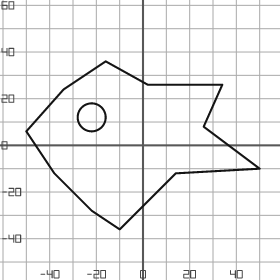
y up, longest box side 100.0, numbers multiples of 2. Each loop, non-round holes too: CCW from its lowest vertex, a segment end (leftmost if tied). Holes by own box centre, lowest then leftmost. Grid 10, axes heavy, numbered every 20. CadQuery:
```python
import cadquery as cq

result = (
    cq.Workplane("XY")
    .moveTo(-10.0, -36.0)
    .lineTo(14.0, -12.0)
    .lineTo(50.0, -10.0)
    .lineTo(26.0, 8.0)
    .lineTo(34.0, 26.0)
    .lineTo(2.0, 26.0)
    .lineTo(-16.0, 36.0)
    .lineTo(-34.0, 24.0)
    .lineTo(-50.0, 6.0)
    .lineTo(-38.0, -12.0)
    .lineTo(-22.0, -28.0)
    .close()
    .moveTo(-22.0, 12.0)
    .circle(6.0)
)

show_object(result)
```